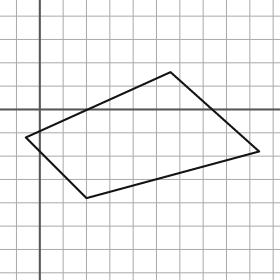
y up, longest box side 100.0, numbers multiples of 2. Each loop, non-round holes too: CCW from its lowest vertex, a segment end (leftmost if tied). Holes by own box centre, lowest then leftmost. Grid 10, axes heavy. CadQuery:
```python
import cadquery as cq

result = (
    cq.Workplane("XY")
    .moveTo(20.0, -38.0)
    .lineTo(94.0, -18.0)
    .lineTo(56.0, 16.0)
    .lineTo(-6.0, -12.0)
    .close()
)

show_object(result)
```